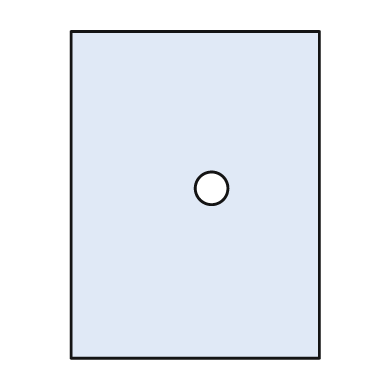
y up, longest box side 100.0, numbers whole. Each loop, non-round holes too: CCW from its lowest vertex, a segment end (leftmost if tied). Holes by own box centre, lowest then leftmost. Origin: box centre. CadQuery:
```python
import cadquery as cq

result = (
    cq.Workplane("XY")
    .moveTo(-38.0, -50.0)
    .lineTo(38.0, -50.0)
    .lineTo(38.0, 50.0)
    .lineTo(-38.0, 50.0)
    .close()
    .moveTo(5.0, 2.0)
    .circle(5.0)
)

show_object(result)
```